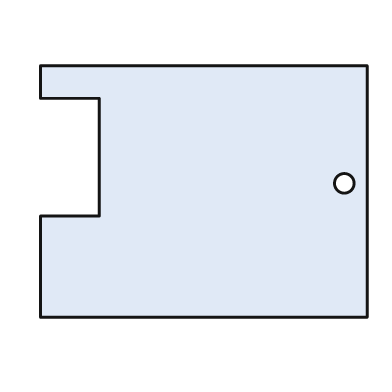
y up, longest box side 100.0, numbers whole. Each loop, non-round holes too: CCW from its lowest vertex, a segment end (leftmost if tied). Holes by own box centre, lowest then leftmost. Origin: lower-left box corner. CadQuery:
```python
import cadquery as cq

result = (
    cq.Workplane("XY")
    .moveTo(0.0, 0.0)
    .lineTo(100.0, 0.0)
    .lineTo(100.0, 77.0)
    .lineTo(0.0, 77.0)
    .lineTo(0.0, 67.0)
    .lineTo(18.0, 67.0)
    .lineTo(18.0, 31.0)
    .lineTo(0.0, 31.0)
    .close()
    .moveTo(93.0, 41.0)
    .circle(3.0)
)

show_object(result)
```